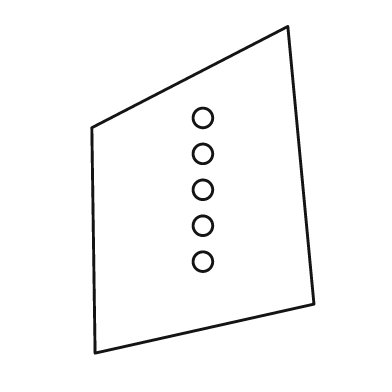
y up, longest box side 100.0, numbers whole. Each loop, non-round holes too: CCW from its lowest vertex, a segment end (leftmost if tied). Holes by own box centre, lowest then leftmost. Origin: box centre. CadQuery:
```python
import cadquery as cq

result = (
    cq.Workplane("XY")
    .moveTo(-33.0, -50.0)
    .lineTo(34.0, -35.0)
    .lineTo(26.0, 50.0)
    .lineTo(-34.0, 19.0)
    .close()
    .moveTo(0.0, -22.0)
    .circle(3.0)
    .moveTo(0.0, -11.0)
    .circle(3.0)
    .moveTo(0.0, 0.0)
    .circle(3.0)
    .moveTo(0.0, 11.0)
    .circle(3.0)
    .moveTo(0.0, 22.0)
    .circle(3.0)
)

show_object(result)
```